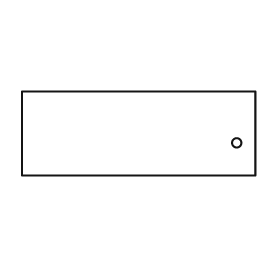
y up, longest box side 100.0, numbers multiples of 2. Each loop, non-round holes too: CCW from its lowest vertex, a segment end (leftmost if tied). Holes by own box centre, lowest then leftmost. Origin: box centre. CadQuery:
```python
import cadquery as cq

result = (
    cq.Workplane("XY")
    .moveTo(-50.0, -18.0)
    .lineTo(50.0, -18.0)
    .lineTo(50.0, 18.0)
    .lineTo(-50.0, 18.0)
    .close()
    .moveTo(42.0, -4.0)
    .circle(2.0)
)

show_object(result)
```